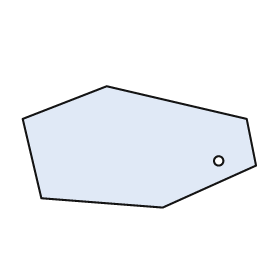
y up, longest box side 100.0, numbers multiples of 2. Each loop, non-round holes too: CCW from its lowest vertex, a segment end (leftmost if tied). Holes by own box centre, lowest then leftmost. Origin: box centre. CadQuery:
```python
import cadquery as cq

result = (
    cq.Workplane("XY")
    .moveTo(10.0, -26.0)
    .lineTo(50.0, -8.0)
    .lineTo(46.0, 12.0)
    .lineTo(-14.0, 26.0)
    .lineTo(-50.0, 12.0)
    .lineTo(-42.0, -22.0)
    .close()
    .moveTo(34.0, -6.0)
    .circle(2.0)
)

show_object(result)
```